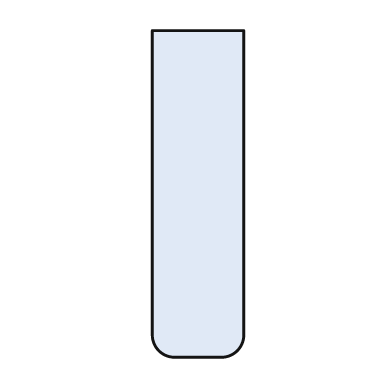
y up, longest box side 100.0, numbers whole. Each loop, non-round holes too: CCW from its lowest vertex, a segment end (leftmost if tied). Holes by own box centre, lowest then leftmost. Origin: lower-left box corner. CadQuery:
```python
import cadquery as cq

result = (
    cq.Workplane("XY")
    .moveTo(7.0, 0.0)
    .lineTo(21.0, 0.0)
    .threePointArc((26.0, 2.0), (28.0, 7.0))
    .lineTo(28.0, 100.0)
    .lineTo(0.0, 100.0)
    .lineTo(0.0, 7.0)
    .threePointArc((2.0, 2.0), (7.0, 0.0))
    .close()
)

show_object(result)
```